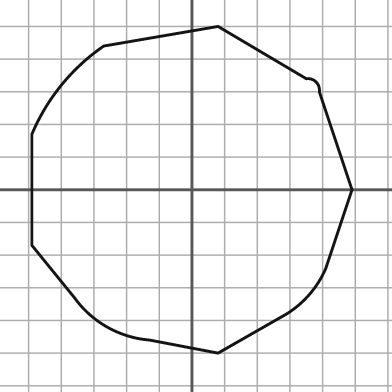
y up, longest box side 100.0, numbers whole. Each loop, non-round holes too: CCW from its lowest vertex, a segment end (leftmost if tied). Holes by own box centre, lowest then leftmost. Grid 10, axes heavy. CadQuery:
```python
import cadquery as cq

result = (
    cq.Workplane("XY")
    .moveTo(8.0, -50.0)
    .lineTo(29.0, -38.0)
    .threePointArc((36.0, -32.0), (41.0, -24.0))
    .lineTo(49.0, 0.0)
    .lineTo(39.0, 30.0)
    .threePointArc((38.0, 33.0), (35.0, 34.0))
    .lineTo(8.0, 50.0)
    .lineTo(-27.0, 44.0)
    .threePointArc((-40.0, 32.0), (-49.0, 17.0))
    .lineTo(-49.0, -17.0)
    .lineTo(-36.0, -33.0)
    .threePointArc((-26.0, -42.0), (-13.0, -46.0))
    .close()
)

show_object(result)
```